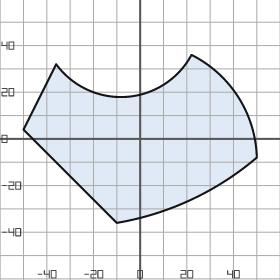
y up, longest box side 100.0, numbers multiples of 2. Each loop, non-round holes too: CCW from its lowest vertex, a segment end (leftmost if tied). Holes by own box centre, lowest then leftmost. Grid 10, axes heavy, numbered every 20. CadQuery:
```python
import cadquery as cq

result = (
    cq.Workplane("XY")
    .moveTo(-10.0, -36.0)
    .threePointArc((22.0, -26.0), (50.0, -8.0))
    .threePointArc((42.0, 18.0), (22.0, 36.0))
    .threePointArc((-6.0, 18.0), (-36.0, 32.0))
    .lineTo(-50.0, 4.0)
    .close()
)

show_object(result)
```